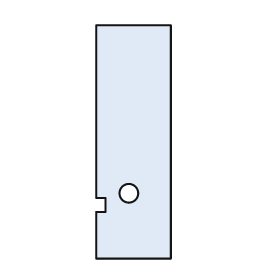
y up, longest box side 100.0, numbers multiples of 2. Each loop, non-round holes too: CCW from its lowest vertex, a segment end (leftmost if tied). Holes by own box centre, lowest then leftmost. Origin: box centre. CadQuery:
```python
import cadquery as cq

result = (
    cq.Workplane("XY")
    .moveTo(-16.0, -50.0)
    .lineTo(16.0, -50.0)
    .lineTo(16.0, 50.0)
    .lineTo(-16.0, 50.0)
    .lineTo(-16.0, -24.0)
    .lineTo(-12.0, -24.0)
    .lineTo(-12.0, -30.0)
    .lineTo(-16.0, -30.0)
    .close()
    .moveTo(-2.0, -22.0)
    .circle(4.0)
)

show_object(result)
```